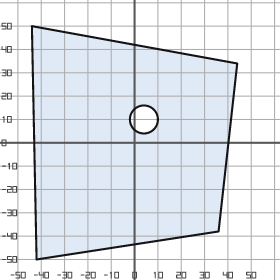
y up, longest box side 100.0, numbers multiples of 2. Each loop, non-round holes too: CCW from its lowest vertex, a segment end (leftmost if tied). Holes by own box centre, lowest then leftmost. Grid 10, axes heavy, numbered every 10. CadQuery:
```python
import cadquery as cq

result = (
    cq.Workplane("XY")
    .moveTo(-42.0, -50.0)
    .lineTo(36.0, -38.0)
    .lineTo(44.0, 34.0)
    .lineTo(-44.0, 50.0)
    .close()
    .moveTo(4.0, 10.0)
    .circle(6.0)
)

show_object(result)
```